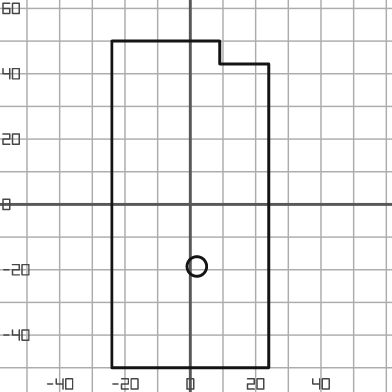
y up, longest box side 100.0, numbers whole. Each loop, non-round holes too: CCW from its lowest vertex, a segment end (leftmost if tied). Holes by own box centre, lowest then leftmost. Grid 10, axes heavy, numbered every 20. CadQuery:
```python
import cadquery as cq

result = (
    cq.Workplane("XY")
    .moveTo(-24.0, -50.0)
    .lineTo(24.0, -50.0)
    .lineTo(24.0, 43.0)
    .lineTo(9.0, 43.0)
    .lineTo(9.0, 50.0)
    .lineTo(-24.0, 50.0)
    .close()
    .moveTo(2.0, -19.0)
    .circle(3.0)
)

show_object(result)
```